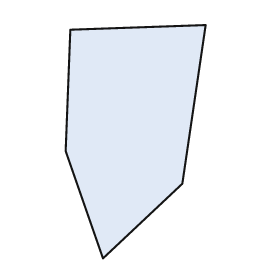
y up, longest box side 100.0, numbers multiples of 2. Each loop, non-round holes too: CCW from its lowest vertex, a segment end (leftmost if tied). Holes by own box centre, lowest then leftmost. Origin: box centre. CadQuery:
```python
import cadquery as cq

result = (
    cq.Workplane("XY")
    .moveTo(-14.0, -50.0)
    .lineTo(20.0, -18.0)
    .lineTo(30.0, 50.0)
    .lineTo(-28.0, 48.0)
    .lineTo(-30.0, -4.0)
    .close()
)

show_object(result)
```